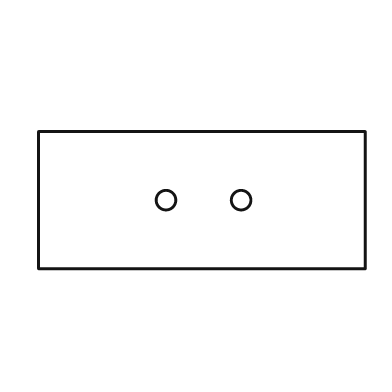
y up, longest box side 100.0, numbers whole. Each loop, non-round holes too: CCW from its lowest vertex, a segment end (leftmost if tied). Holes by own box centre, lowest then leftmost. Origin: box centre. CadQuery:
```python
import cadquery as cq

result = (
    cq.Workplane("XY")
    .moveTo(-50.0, -21.0)
    .lineTo(50.0, -21.0)
    .lineTo(50.0, 21.0)
    .lineTo(-50.0, 21.0)
    .close()
    .moveTo(-11.0, 0.0)
    .circle(3.0)
    .moveTo(12.0, 0.0)
    .circle(3.0)
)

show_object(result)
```